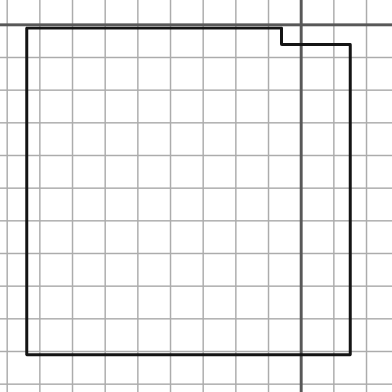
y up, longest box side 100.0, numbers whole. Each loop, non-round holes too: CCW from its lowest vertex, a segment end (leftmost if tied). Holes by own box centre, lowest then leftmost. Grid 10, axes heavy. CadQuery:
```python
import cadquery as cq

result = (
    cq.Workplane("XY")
    .moveTo(-84.0, -101.0)
    .lineTo(15.0, -101.0)
    .lineTo(15.0, -6.0)
    .lineTo(-6.0, -6.0)
    .lineTo(-6.0, -1.0)
    .lineTo(-84.0, -1.0)
    .close()
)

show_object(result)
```